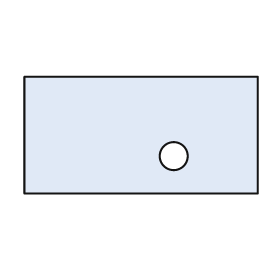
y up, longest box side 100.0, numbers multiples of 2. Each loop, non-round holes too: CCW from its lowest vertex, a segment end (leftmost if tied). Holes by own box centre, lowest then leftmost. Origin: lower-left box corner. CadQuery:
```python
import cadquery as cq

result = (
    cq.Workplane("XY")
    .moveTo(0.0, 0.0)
    .lineTo(100.0, 0.0)
    .lineTo(100.0, 50.0)
    .lineTo(0.0, 50.0)
    .close()
    .moveTo(64.0, 16.0)
    .circle(6.0)
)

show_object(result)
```